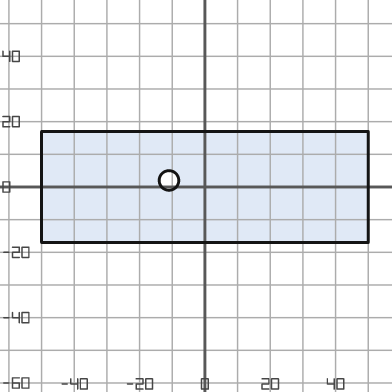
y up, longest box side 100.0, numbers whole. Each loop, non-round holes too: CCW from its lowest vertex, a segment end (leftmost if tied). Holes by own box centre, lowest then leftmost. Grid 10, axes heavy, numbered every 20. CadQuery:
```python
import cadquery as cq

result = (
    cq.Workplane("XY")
    .moveTo(-50.0, -17.0)
    .lineTo(50.0, -17.0)
    .lineTo(50.0, 17.0)
    .lineTo(-50.0, 17.0)
    .close()
    .moveTo(-11.0, 2.0)
    .circle(3.0)
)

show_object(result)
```